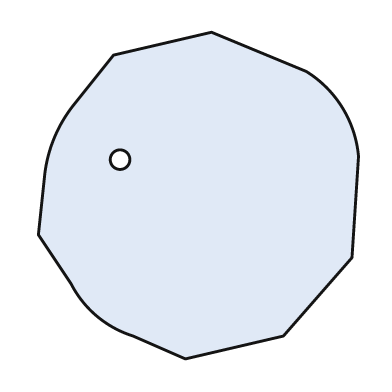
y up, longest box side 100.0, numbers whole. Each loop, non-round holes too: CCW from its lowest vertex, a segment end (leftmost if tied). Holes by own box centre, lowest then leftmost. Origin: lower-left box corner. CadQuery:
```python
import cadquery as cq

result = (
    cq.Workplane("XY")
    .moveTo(45.0, 0.0)
    .lineTo(75.0, 7.0)
    .lineTo(96.0, 31.0)
    .lineTo(98.0, 62.0)
    .threePointArc((93.0, 77.0), (82.0, 88.0))
    .lineTo(53.0, 100.0)
    .lineTo(23.0, 93.0)
    .lineTo(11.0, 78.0)
    .threePointArc((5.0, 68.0), (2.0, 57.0))
    .lineTo(0.0, 38.0)
    .lineTo(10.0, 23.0)
    .threePointArc((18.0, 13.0), (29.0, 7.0))
    .close()
    .moveTo(25.0, 61.0)
    .circle(3.0)
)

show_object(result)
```